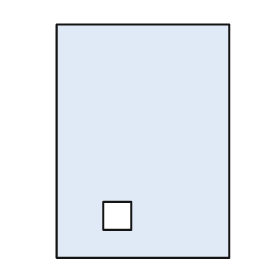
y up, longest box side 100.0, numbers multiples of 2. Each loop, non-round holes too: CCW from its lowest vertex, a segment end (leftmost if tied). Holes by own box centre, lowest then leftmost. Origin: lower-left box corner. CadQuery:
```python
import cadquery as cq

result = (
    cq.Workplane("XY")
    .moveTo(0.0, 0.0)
    .lineTo(74.0, 0.0)
    .lineTo(74.0, 100.0)
    .lineTo(0.0, 100.0)
    .close()
    .moveTo(20.0, 12.0)
    .lineTo(32.0, 12.0)
    .lineTo(32.0, 24.0)
    .lineTo(20.0, 24.0)
    .close()
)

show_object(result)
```